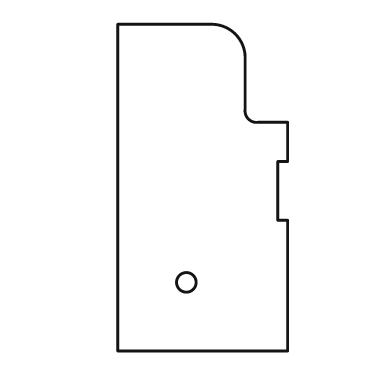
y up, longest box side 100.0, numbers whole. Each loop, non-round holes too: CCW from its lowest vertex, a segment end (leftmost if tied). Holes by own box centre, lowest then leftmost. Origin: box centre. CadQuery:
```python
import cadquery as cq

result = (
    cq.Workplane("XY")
    .moveTo(-26.0, -50.0)
    .lineTo(26.0, -50.0)
    .lineTo(26.0, -10.0)
    .lineTo(23.0, -10.0)
    .lineTo(23.0, 8.0)
    .lineTo(26.0, 8.0)
    .lineTo(26.0, 20.0)
    .lineTo(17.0, 20.0)
    .threePointArc((14.0, 21.0), (13.0, 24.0))
    .lineTo(13.0, 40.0)
    .threePointArc((10.0, 47.0), (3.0, 50.0))
    .lineTo(-26.0, 50.0)
    .close()
    .moveTo(-5.0, -29.0)
    .circle(3.0)
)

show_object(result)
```